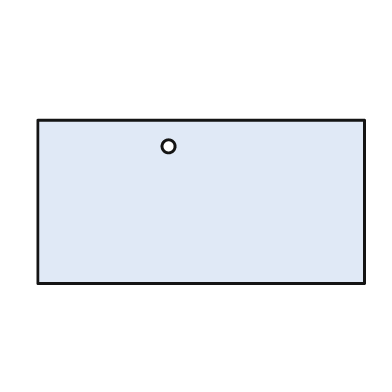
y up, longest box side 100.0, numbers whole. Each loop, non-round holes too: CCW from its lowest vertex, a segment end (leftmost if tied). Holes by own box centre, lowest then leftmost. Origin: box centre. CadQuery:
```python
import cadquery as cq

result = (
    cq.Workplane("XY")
    .moveTo(-50.0, -25.0)
    .lineTo(50.0, -25.0)
    .lineTo(50.0, 25.0)
    .lineTo(-50.0, 25.0)
    .close()
    .moveTo(-10.0, 17.0)
    .circle(2.0)
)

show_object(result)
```